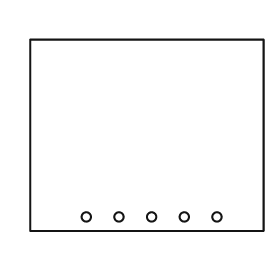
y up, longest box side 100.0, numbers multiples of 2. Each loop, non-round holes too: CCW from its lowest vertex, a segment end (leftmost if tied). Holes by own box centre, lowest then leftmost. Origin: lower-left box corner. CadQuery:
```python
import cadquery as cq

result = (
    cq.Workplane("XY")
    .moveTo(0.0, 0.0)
    .lineTo(100.0, 0.0)
    .lineTo(100.0, 82.0)
    .lineTo(0.0, 82.0)
    .close()
    .moveTo(24.0, 6.0)
    .circle(2.0)
    .moveTo(38.0, 6.0)
    .circle(2.0)
    .moveTo(52.0, 6.0)
    .circle(2.0)
    .moveTo(66.0, 6.0)
    .circle(2.0)
    .moveTo(80.0, 6.0)
    .circle(2.0)
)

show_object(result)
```